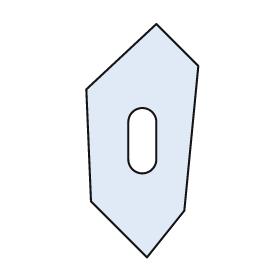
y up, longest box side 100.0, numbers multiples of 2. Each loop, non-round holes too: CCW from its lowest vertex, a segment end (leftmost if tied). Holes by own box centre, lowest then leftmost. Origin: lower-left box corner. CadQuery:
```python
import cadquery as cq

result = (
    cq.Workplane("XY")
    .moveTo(26.0, 0.0)
    .lineTo(42.0, 20.0)
    .lineTo(48.0, 82.0)
    .lineTo(30.0, 100.0)
    .lineTo(0.0, 72.0)
    .lineTo(2.0, 24.0)
    .close()
    .moveTo(18.0, 42.0)
    .threePointArc((24.0, 36.0), (30.0, 42.0))
    .lineTo(30.0, 58.0)
    .threePointArc((24.0, 64.0), (18.0, 58.0))
    .close()
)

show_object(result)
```